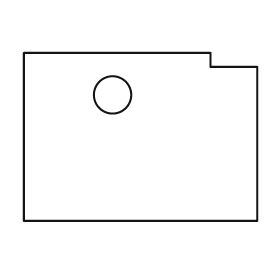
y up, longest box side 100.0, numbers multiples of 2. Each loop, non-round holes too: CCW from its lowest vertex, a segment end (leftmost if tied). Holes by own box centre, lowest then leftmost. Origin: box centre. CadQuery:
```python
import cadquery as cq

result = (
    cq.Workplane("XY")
    .moveTo(-50.0, -36.0)
    .lineTo(50.0, -36.0)
    .lineTo(50.0, 30.0)
    .lineTo(30.0, 30.0)
    .lineTo(30.0, 36.0)
    .lineTo(-50.0, 36.0)
    .close()
    .moveTo(-12.0, 18.0)
    .circle(8.0)
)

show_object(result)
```